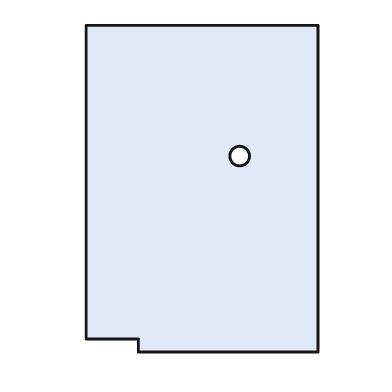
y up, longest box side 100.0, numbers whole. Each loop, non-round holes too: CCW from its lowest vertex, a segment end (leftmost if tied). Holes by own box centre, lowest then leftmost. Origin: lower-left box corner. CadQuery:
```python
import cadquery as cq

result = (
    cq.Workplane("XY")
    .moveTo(16.0, 0.0)
    .lineTo(71.0, 0.0)
    .lineTo(71.0, 100.0)
    .lineTo(0.0, 100.0)
    .lineTo(0.0, 4.0)
    .lineTo(16.0, 4.0)
    .close()
    .moveTo(47.0, 60.0)
    .circle(3.0)
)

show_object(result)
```